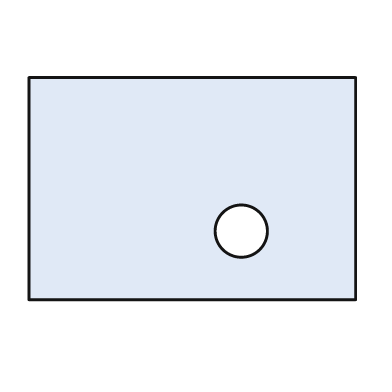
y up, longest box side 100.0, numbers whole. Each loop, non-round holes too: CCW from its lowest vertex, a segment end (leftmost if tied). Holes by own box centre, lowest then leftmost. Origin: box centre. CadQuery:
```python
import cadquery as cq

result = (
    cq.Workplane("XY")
    .moveTo(-50.0, -34.0)
    .lineTo(50.0, -34.0)
    .lineTo(50.0, 34.0)
    .lineTo(-50.0, 34.0)
    .close()
    .moveTo(15.0, -13.0)
    .circle(8.0)
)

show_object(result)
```